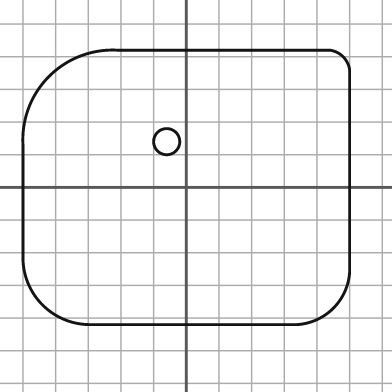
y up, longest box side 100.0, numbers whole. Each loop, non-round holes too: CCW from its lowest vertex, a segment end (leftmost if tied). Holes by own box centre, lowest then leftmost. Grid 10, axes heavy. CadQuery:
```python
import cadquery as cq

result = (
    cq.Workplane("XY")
    .moveTo(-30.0, -42.0)
    .lineTo(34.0, -42.0)
    .threePointArc((45.0, -37.0), (50.0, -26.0))
    .lineTo(50.0, 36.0)
    .threePointArc((48.0, 40.0), (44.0, 42.0))
    .lineTo(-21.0, 42.0)
    .threePointArc((-42.0, 34.0), (-50.0, 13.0))
    .lineTo(-50.0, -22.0)
    .threePointArc((-44.0, -36.0), (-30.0, -42.0))
    .close()
    .moveTo(-6.0, 14.0)
    .circle(4.0)
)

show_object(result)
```